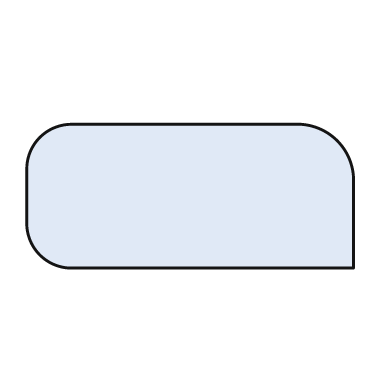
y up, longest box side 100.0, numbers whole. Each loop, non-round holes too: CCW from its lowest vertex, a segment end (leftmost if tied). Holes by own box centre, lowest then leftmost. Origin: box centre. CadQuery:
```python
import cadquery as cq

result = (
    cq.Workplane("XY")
    .moveTo(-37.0, -22.0)
    .lineTo(50.0, -22.0)
    .lineTo(50.0, 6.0)
    .threePointArc((45.0, 17.0), (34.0, 22.0))
    .lineTo(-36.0, 22.0)
    .threePointArc((-46.0, 18.0), (-50.0, 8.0))
    .lineTo(-50.0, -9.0)
    .threePointArc((-46.0, -18.0), (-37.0, -22.0))
    .close()
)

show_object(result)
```